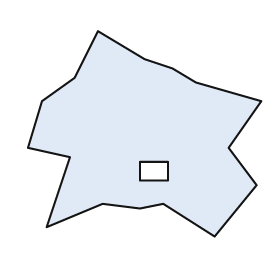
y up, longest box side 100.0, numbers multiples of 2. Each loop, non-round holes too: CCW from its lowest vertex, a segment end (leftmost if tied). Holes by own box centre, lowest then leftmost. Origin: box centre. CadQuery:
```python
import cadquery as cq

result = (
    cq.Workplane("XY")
    .moveTo(30.0, -44.0)
    .lineTo(48.0, -22.0)
    .lineTo(36.0, -6.0)
    .lineTo(50.0, 14.0)
    .lineTo(22.0, 22.0)
    .lineTo(12.0, 28.0)
    .lineTo(0.0, 32.0)
    .lineTo(-20.0, 44.0)
    .lineTo(-30.0, 24.0)
    .lineTo(-44.0, 14.0)
    .lineTo(-50.0, -6.0)
    .lineTo(-32.0, -10.0)
    .lineTo(-42.0, -40.0)
    .lineTo(-18.0, -30.0)
    .lineTo(-2.0, -32.0)
    .lineTo(8.0, -30.0)
    .close()
    .moveTo(-2.0, -20.0)
    .lineTo(10.0, -20.0)
    .lineTo(10.0, -12.0)
    .lineTo(-2.0, -12.0)
    .close()
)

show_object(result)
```